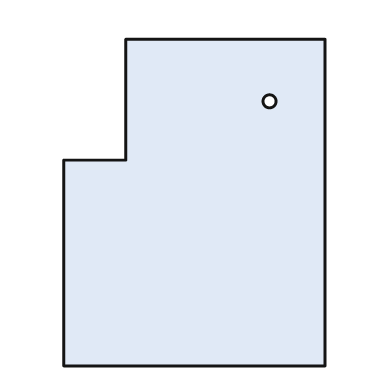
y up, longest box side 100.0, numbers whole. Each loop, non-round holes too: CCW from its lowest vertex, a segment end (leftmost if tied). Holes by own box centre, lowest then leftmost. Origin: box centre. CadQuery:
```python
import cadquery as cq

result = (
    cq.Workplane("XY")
    .moveTo(-40.0, -50.0)
    .lineTo(40.0, -50.0)
    .lineTo(40.0, 50.0)
    .lineTo(-21.0, 50.0)
    .lineTo(-21.0, 13.0)
    .lineTo(-40.0, 13.0)
    .close()
    .moveTo(23.0, 31.0)
    .circle(2.0)
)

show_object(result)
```